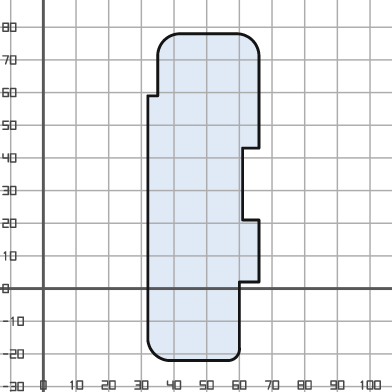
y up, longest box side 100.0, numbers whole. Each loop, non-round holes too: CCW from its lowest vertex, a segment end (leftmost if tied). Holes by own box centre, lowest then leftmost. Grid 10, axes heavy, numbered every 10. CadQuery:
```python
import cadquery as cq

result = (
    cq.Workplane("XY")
    .moveTo(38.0, -22.0)
    .lineTo(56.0, -22.0)
    .threePointArc((59.0, -21.0), (60.0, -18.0))
    .lineTo(60.0, 2.0)
    .lineTo(66.0, 2.0)
    .lineTo(66.0, 21.0)
    .lineTo(61.0, 21.0)
    .lineTo(61.0, 43.0)
    .lineTo(66.0, 43.0)
    .lineTo(66.0, 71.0)
    .threePointArc((64.0, 76.0), (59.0, 78.0))
    .lineTo(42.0, 78.0)
    .threePointArc((37.0, 76.0), (35.0, 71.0))
    .lineTo(35.0, 59.0)
    .lineTo(32.0, 59.0)
    .lineTo(32.0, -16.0)
    .threePointArc((34.0, -20.0), (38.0, -22.0))
    .close()
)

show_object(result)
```